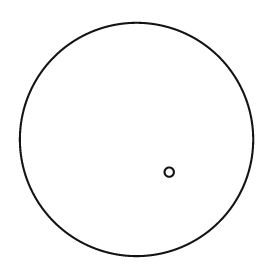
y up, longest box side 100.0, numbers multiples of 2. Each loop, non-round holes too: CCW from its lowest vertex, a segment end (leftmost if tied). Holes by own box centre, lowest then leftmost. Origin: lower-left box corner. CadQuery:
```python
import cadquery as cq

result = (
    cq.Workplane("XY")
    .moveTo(50.0, 50.0)
    .circle(50.0)
    .moveTo(64.0, 36.0)
    .circle(2.0)
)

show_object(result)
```